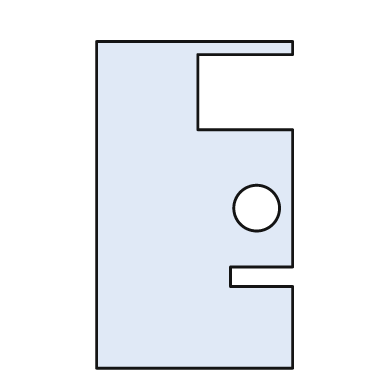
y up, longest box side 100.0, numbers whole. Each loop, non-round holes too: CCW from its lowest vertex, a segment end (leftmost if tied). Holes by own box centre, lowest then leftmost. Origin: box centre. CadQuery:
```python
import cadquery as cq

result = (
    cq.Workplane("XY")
    .moveTo(-30.0, -50.0)
    .lineTo(30.0, -50.0)
    .lineTo(30.0, -25.0)
    .lineTo(11.0, -25.0)
    .lineTo(11.0, -19.0)
    .lineTo(30.0, -19.0)
    .lineTo(30.0, 23.0)
    .lineTo(1.0, 23.0)
    .lineTo(1.0, 46.0)
    .lineTo(30.0, 46.0)
    .lineTo(30.0, 50.0)
    .lineTo(-30.0, 50.0)
    .close()
    .moveTo(19.0, -1.0)
    .circle(7.0)
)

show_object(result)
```